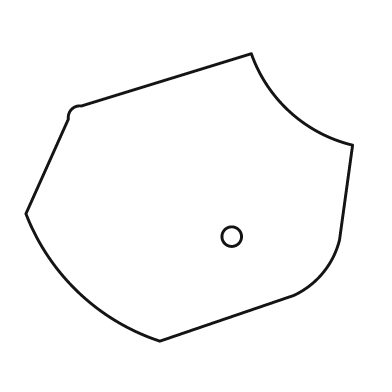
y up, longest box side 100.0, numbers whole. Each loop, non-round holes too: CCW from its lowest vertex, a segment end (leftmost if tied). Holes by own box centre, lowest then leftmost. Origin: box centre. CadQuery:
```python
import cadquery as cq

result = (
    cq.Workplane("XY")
    .moveTo(-9.0, -44.0)
    .lineTo(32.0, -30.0)
    .threePointArc((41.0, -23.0), (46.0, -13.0))
    .lineTo(50.0, 16.0)
    .threePointArc((31.0, 26.0), (19.0, 44.0))
    .lineTo(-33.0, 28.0)
    .threePointArc((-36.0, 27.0), (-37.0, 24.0))
    .lineTo(-50.0, -5.0)
    .threePointArc((-34.0, -29.0), (-9.0, -44.0))
    .close()
    .moveTo(13.0, -12.0)
    .circle(3.0)
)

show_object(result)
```